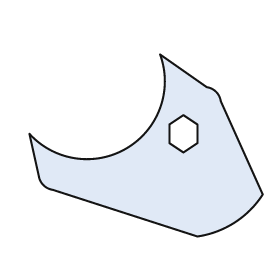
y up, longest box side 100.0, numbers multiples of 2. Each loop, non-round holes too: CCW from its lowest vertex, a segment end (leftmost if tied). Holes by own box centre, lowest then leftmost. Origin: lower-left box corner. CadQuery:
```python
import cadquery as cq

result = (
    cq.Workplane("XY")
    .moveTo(72.0, 0.0)
    .threePointArc((88.0, 6.0), (100.0, 18.0))
    .lineTo(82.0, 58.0)
    .threePointArc((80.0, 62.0), (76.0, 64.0))
    .lineTo(56.0, 78.0)
    .threePointArc((42.0, 38.0), (0.0, 44.0))
    .lineTo(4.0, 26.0)
    .threePointArc((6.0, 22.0), (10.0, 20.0))
    .close()
    .moveTo(66.0, 36.0)
    .lineTo(72.0, 40.0)
    .lineTo(72.0, 48.0)
    .lineTo(66.0, 52.0)
    .lineTo(60.0, 48.0)
    .lineTo(60.0, 40.0)
    .close()
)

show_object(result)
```